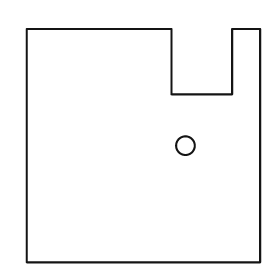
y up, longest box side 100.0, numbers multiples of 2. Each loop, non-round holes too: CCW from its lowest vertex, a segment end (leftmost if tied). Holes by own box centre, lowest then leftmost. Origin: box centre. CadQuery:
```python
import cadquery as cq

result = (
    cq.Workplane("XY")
    .moveTo(-50.0, -50.0)
    .lineTo(50.0, -50.0)
    .lineTo(50.0, 50.0)
    .lineTo(38.0, 50.0)
    .lineTo(38.0, 22.0)
    .lineTo(12.0, 22.0)
    .lineTo(12.0, 50.0)
    .lineTo(-50.0, 50.0)
    .close()
    .moveTo(18.0, 0.0)
    .circle(4.0)
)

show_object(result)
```